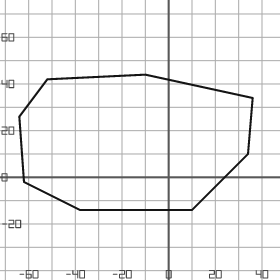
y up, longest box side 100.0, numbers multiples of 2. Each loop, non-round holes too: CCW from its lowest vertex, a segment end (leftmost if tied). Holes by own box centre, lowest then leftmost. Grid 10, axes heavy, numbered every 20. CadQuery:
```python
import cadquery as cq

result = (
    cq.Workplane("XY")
    .moveTo(-38.0, -14.0)
    .lineTo(10.0, -14.0)
    .lineTo(34.0, 10.0)
    .lineTo(36.0, 34.0)
    .lineTo(-10.0, 44.0)
    .lineTo(-52.0, 42.0)
    .lineTo(-64.0, 26.0)
    .lineTo(-62.0, -2.0)
    .close()
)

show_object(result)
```